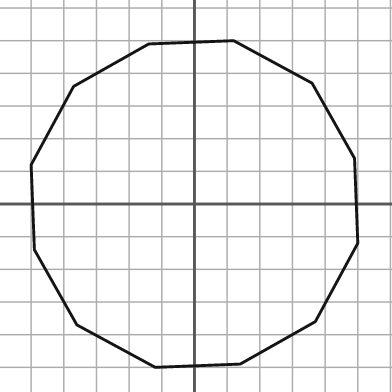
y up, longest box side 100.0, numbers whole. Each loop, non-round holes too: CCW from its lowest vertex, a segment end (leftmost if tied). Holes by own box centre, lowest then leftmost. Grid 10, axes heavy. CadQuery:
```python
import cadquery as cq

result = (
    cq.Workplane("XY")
    .moveTo(-12.0, -50.0)
    .lineTo(14.0, -49.0)
    .lineTo(37.0, -36.0)
    .lineTo(50.0, -12.0)
    .lineTo(49.0, 14.0)
    .lineTo(36.0, 37.0)
    .lineTo(12.0, 50.0)
    .lineTo(-14.0, 49.0)
    .lineTo(-37.0, 36.0)
    .lineTo(-50.0, 12.0)
    .lineTo(-49.0, -14.0)
    .lineTo(-36.0, -37.0)
    .close()
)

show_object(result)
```